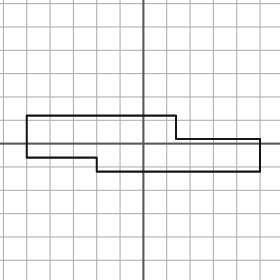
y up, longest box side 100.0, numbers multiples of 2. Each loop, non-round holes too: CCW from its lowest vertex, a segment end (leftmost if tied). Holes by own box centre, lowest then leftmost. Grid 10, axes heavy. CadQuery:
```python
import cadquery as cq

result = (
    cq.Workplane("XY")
    .moveTo(-20.0, -12.0)
    .lineTo(50.0, -12.0)
    .lineTo(50.0, 2.0)
    .lineTo(14.0, 2.0)
    .lineTo(14.0, 12.0)
    .lineTo(-50.0, 12.0)
    .lineTo(-50.0, -6.0)
    .lineTo(-20.0, -6.0)
    .close()
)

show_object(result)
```